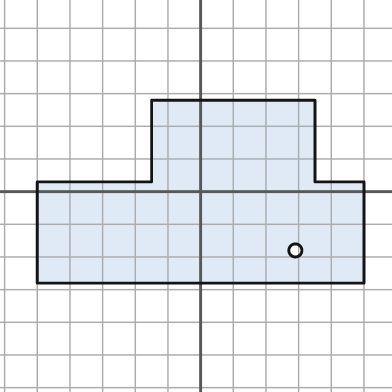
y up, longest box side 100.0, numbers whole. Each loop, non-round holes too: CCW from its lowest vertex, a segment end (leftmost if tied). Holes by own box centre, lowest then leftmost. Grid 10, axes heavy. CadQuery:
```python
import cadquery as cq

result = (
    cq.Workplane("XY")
    .moveTo(-50.0, -28.0)
    .lineTo(50.0, -28.0)
    .lineTo(50.0, 3.0)
    .lineTo(35.0, 3.0)
    .lineTo(35.0, 28.0)
    .lineTo(-15.0, 28.0)
    .lineTo(-15.0, 3.0)
    .lineTo(-50.0, 3.0)
    .close()
    .moveTo(29.0, -18.0)
    .circle(2.0)
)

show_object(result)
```